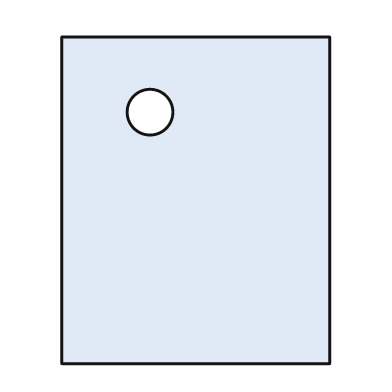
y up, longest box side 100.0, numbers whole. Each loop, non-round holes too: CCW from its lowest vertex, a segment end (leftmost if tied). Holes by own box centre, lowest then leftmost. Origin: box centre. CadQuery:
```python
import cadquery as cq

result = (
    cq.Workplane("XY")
    .moveTo(-41.0, -50.0)
    .lineTo(41.0, -50.0)
    .lineTo(41.0, 50.0)
    .lineTo(-41.0, 50.0)
    .close()
    .moveTo(-14.0, 27.0)
    .circle(7.0)
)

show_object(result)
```